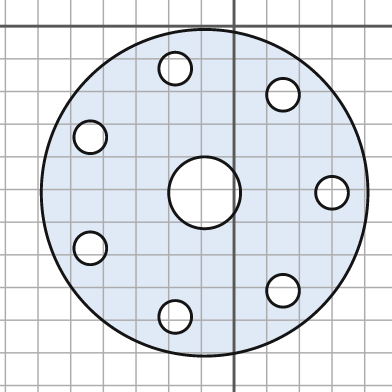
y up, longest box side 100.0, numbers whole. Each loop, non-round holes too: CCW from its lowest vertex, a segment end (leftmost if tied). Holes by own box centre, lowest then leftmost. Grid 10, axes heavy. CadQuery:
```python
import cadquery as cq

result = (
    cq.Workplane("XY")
    .moveTo(-9.0, -51.0)
    .circle(50.0)
    .moveTo(-18.0, -89.0)
    .circle(5.0)
    .moveTo(15.0, -81.0)
    .circle(5.0)
    .moveTo(-44.0, -68.0)
    .circle(5.0)
    .moveTo(-9.0, -51.0)
    .circle(11.0)
    .moveTo(30.0, -51.0)
    .circle(5.0)
    .moveTo(-44.0, -34.0)
    .circle(5.0)
    .moveTo(15.0, -21.0)
    .circle(5.0)
    .moveTo(-18.0, -13.0)
    .circle(5.0)
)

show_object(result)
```